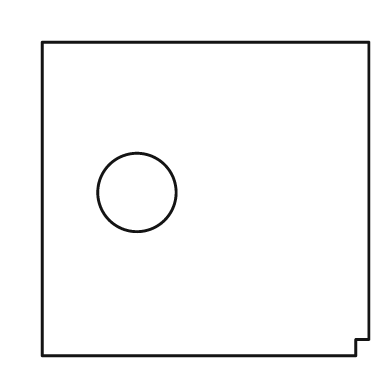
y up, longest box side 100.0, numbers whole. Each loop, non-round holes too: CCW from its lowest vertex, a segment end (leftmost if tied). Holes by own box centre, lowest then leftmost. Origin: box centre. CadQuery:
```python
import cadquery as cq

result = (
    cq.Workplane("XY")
    .moveTo(-50.0, -48.0)
    .lineTo(46.0, -48.0)
    .lineTo(46.0, -43.0)
    .lineTo(50.0, -43.0)
    .lineTo(50.0, 48.0)
    .lineTo(-50.0, 48.0)
    .close()
    .moveTo(-21.0, 2.0)
    .circle(12.0)
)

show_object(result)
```